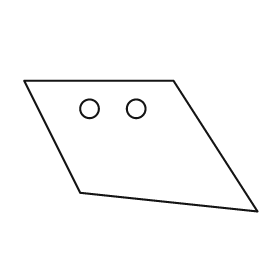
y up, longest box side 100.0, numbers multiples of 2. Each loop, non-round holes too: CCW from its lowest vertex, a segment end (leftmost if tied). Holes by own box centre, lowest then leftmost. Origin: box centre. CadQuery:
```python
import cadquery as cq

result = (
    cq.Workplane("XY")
    .moveTo(50.0, -28.0)
    .lineTo(14.0, 28.0)
    .lineTo(-50.0, 28.0)
    .lineTo(-26.0, -20.0)
    .close()
    .moveTo(-22.0, 16.0)
    .circle(4.0)
    .moveTo(-2.0, 16.0)
    .circle(4.0)
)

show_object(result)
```